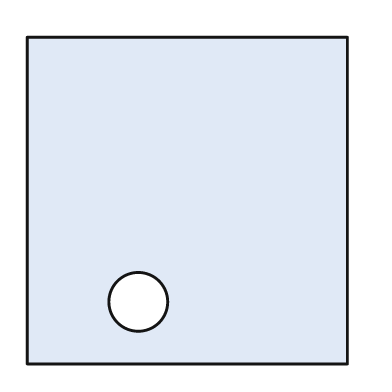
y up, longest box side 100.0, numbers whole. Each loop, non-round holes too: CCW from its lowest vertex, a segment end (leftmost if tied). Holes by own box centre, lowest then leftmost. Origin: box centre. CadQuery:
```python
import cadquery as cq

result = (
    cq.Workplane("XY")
    .moveTo(-49.0, -50.0)
    .lineTo(49.0, -50.0)
    .lineTo(49.0, 50.0)
    .lineTo(-49.0, 50.0)
    .close()
    .moveTo(-15.0, -31.0)
    .circle(9.0)
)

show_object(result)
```